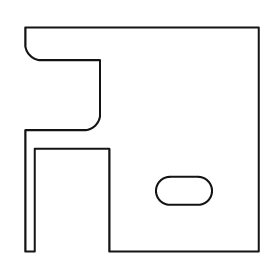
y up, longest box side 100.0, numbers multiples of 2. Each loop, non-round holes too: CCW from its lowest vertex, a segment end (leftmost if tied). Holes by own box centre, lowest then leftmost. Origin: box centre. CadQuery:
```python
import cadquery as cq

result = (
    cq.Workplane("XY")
    .moveTo(-50.0, -48.0)
    .lineTo(-46.0, -48.0)
    .lineTo(-46.0, -4.0)
    .lineTo(-14.0, -4.0)
    .lineTo(-14.0, -48.0)
    .lineTo(50.0, -48.0)
    .lineTo(50.0, 48.0)
    .lineTo(-50.0, 48.0)
    .lineTo(-50.0, 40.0)
    .threePointArc((-48.0, 36.0), (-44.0, 34.0))
    .lineTo(-18.0, 34.0)
    .lineTo(-18.0, 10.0)
    .threePointArc((-20.0, 6.0), (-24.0, 4.0))
    .lineTo(-50.0, 4.0)
    .close()
    .moveTo(12.0, -28.0)
    .lineTo(24.0, -28.0)
    .threePointArc((30.0, -22.0), (24.0, -16.0))
    .lineTo(12.0, -16.0)
    .threePointArc((6.0, -22.0), (12.0, -28.0))
    .close()
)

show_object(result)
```